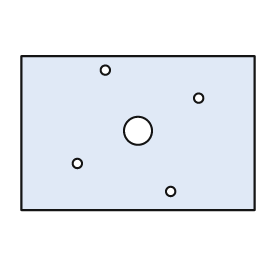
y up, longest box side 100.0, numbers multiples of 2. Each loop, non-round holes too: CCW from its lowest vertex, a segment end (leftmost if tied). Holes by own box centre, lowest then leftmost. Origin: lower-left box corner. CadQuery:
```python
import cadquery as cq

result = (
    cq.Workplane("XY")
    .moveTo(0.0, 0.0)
    .lineTo(100.0, 0.0)
    .lineTo(100.0, 66.0)
    .lineTo(0.0, 66.0)
    .close()
    .moveTo(64.0, 8.0)
    .circle(2.0)
    .moveTo(24.0, 20.0)
    .circle(2.0)
    .moveTo(50.0, 34.0)
    .circle(6.0)
    .moveTo(76.0, 48.0)
    .circle(2.0)
    .moveTo(36.0, 60.0)
    .circle(2.0)
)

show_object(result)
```